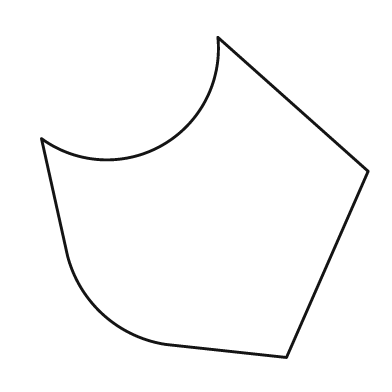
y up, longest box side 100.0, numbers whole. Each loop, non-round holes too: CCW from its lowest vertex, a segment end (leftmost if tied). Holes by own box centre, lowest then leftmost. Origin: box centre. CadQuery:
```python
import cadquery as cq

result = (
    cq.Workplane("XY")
    .moveTo(25.0, -49.0)
    .lineTo(50.0, 8.0)
    .lineTo(4.0, 49.0)
    .threePointArc((-13.0, 16.0), (-50.0, 18.0))
    .lineTo(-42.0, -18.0)
    .threePointArc((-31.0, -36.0), (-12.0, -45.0))
    .close()
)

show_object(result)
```